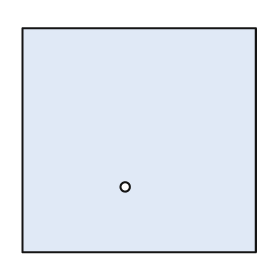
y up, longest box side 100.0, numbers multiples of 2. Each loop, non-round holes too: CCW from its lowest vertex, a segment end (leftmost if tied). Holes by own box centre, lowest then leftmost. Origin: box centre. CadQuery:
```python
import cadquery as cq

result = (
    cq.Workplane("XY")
    .moveTo(-50.0, -48.0)
    .lineTo(50.0, -48.0)
    .lineTo(50.0, 48.0)
    .lineTo(-50.0, 48.0)
    .close()
    .moveTo(-6.0, -20.0)
    .circle(2.0)
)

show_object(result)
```